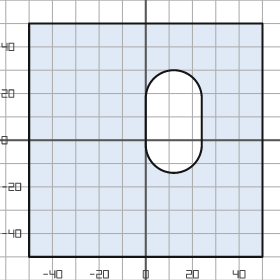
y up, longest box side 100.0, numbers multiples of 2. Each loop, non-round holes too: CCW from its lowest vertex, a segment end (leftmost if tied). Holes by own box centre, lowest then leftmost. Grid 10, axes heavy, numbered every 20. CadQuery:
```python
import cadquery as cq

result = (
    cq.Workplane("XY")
    .moveTo(-50.0, -50.0)
    .lineTo(50.0, -50.0)
    .lineTo(50.0, 50.0)
    .lineTo(-50.0, 50.0)
    .close()
    .moveTo(0.0, -2.0)
    .threePointArc((12.0, -14.0), (24.0, -2.0))
    .lineTo(24.0, 18.0)
    .threePointArc((12.0, 30.0), (0.0, 18.0))
    .close()
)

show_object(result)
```